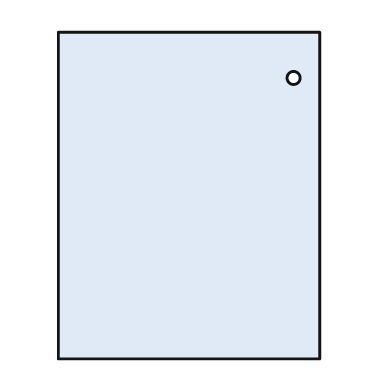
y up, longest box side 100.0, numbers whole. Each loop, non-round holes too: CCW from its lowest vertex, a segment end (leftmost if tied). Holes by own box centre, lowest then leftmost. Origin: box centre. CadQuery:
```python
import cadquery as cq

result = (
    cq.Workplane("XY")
    .moveTo(-40.0, -50.0)
    .lineTo(40.0, -50.0)
    .lineTo(40.0, 50.0)
    .lineTo(-40.0, 50.0)
    .close()
    .moveTo(32.0, 36.0)
    .circle(2.0)
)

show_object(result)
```